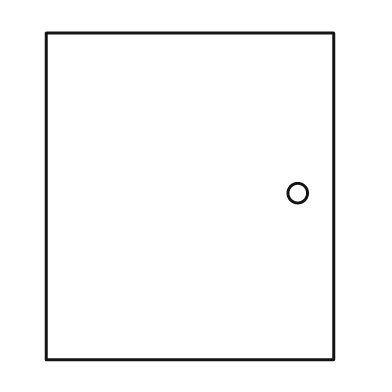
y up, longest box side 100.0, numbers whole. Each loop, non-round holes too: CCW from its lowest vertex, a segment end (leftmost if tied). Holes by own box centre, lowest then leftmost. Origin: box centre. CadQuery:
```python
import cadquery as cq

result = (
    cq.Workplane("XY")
    .moveTo(-44.0, -50.0)
    .lineTo(44.0, -50.0)
    .lineTo(44.0, 50.0)
    .lineTo(-44.0, 50.0)
    .close()
    .moveTo(33.0, 1.0)
    .circle(3.0)
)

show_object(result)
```